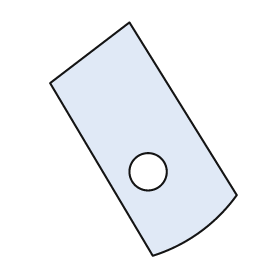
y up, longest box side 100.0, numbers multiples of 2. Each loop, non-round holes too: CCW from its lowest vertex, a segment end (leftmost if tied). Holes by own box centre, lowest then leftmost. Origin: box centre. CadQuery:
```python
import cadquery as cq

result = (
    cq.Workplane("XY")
    .moveTo(4.0, -50.0)
    .threePointArc((24.0, -40.0), (40.0, -24.0))
    .lineTo(-6.0, 50.0)
    .lineTo(-40.0, 24.0)
    .close()
    .moveTo(2.0, -14.0)
    .circle(8.0)
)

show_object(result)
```